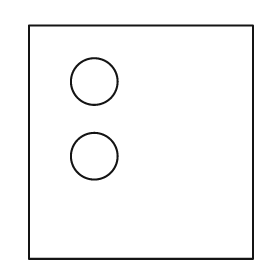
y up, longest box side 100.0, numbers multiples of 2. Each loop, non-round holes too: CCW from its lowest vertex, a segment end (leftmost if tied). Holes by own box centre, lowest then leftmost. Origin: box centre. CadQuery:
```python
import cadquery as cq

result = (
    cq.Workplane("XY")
    .moveTo(-48.0, -50.0)
    .lineTo(48.0, -50.0)
    .lineTo(48.0, 50.0)
    .lineTo(-48.0, 50.0)
    .close()
    .moveTo(-20.0, -6.0)
    .circle(10.0)
    .moveTo(-20.0, 26.0)
    .circle(10.0)
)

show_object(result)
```